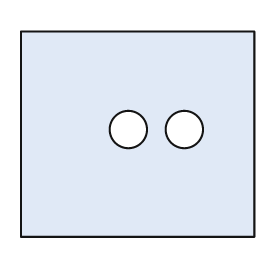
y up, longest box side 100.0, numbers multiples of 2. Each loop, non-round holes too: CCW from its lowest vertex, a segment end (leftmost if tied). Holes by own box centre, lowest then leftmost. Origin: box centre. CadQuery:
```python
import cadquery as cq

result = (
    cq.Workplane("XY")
    .moveTo(-50.0, -44.0)
    .lineTo(50.0, -44.0)
    .lineTo(50.0, 44.0)
    .lineTo(-50.0, 44.0)
    .close()
    .moveTo(-4.0, 2.0)
    .circle(8.0)
    .moveTo(20.0, 2.0)
    .circle(8.0)
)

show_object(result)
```